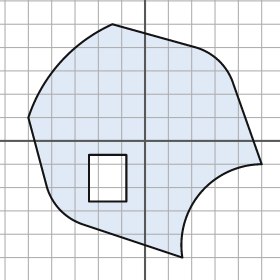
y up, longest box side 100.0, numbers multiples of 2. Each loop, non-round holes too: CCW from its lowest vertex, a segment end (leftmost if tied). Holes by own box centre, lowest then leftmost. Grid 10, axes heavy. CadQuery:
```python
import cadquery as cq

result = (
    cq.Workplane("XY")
    .moveTo(16.0, -50.0)
    .threePointArc((24.0, -22.0), (50.0, -10.0))
    .lineTo(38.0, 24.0)
    .threePointArc((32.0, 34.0), (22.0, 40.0))
    .lineTo(-14.0, 50.0)
    .threePointArc((-36.0, 34.0), (-50.0, 10.0))
    .lineTo(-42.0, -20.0)
    .threePointArc((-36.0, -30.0), (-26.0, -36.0))
    .close()
    .moveTo(-24.0, -26.0)
    .lineTo(-8.0, -26.0)
    .lineTo(-8.0, -6.0)
    .lineTo(-24.0, -6.0)
    .close()
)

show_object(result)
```